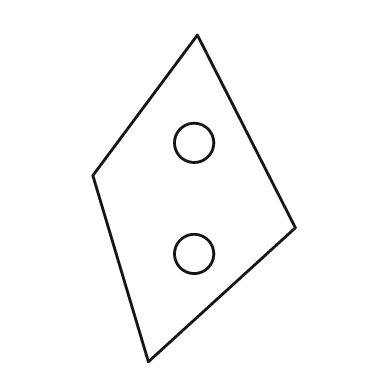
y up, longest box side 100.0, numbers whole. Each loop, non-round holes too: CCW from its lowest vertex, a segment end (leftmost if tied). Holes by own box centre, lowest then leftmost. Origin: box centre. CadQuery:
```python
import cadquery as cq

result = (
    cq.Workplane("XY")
    .moveTo(-14.0, -50.0)
    .lineTo(31.0, -9.0)
    .lineTo(1.0, 50.0)
    .lineTo(-31.0, 7.0)
    .close()
    .moveTo(0.0, -17.0)
    .circle(6.0)
    .moveTo(0.0, 17.0)
    .circle(6.0)
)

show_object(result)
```